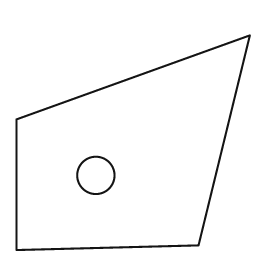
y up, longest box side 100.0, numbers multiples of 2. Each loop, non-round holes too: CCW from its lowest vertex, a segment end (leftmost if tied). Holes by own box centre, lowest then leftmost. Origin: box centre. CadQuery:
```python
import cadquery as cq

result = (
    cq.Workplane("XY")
    .moveTo(-50.0, -46.0)
    .lineTo(28.0, -44.0)
    .lineTo(50.0, 46.0)
    .lineTo(-50.0, 10.0)
    .close()
    .moveTo(-16.0, -14.0)
    .circle(8.0)
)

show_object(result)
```